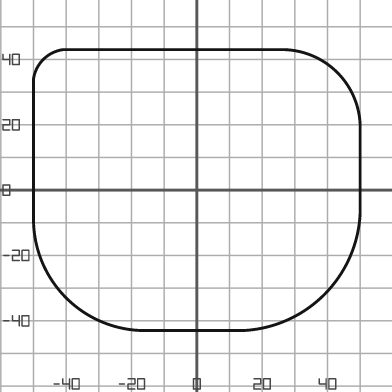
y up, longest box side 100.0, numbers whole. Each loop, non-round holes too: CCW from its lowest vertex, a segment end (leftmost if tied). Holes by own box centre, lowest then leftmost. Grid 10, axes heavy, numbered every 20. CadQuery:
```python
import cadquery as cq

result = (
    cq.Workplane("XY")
    .moveTo(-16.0, -43.0)
    .lineTo(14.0, -43.0)
    .threePointArc((39.0, -32.0), (50.0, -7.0))
    .lineTo(50.0, 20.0)
    .threePointArc((43.0, 36.0), (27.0, 43.0))
    .lineTo(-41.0, 43.0)
    .threePointArc((-47.0, 40.0), (-50.0, 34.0))
    .lineTo(-50.0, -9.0)
    .threePointArc((-40.0, -33.0), (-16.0, -43.0))
    .close()
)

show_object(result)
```